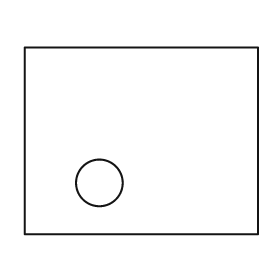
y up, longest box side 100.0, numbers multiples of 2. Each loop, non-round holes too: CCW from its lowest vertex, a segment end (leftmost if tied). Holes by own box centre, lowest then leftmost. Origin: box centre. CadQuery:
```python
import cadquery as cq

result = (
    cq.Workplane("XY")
    .moveTo(-50.0, -40.0)
    .lineTo(50.0, -40.0)
    .lineTo(50.0, 40.0)
    .lineTo(-50.0, 40.0)
    .close()
    .moveTo(-18.0, -18.0)
    .circle(10.0)
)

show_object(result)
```